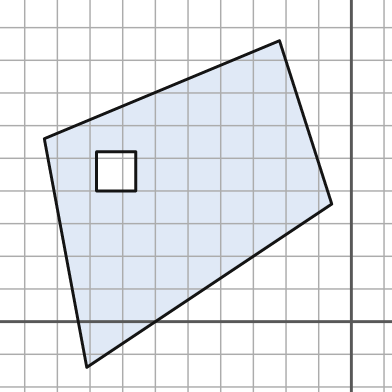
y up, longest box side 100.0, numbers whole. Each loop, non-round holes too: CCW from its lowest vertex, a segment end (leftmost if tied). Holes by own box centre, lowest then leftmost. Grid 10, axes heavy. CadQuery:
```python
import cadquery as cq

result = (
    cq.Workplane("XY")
    .moveTo(-81.0, -14.0)
    .lineTo(-6.0, 36.0)
    .lineTo(-22.0, 86.0)
    .lineTo(-94.0, 56.0)
    .close()
    .moveTo(-78.0, 40.0)
    .lineTo(-66.0, 40.0)
    .lineTo(-66.0, 52.0)
    .lineTo(-78.0, 52.0)
    .close()
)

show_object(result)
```